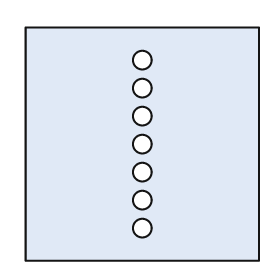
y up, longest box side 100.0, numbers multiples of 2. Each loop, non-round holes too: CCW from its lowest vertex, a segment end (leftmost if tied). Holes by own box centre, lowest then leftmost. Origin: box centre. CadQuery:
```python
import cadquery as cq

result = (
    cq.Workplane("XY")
    .moveTo(-50.0, -50.0)
    .lineTo(50.0, -50.0)
    .lineTo(50.0, 50.0)
    .lineTo(-50.0, 50.0)
    .close()
    .moveTo(0.0, -36.0)
    .circle(4.0)
    .moveTo(0.0, -24.0)
    .circle(4.0)
    .moveTo(0.0, -12.0)
    .circle(4.0)
    .moveTo(0.0, 0.0)
    .circle(4.0)
    .moveTo(0.0, 12.0)
    .circle(4.0)
    .moveTo(0.0, 24.0)
    .circle(4.0)
    .moveTo(0.0, 36.0)
    .circle(4.0)
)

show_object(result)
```